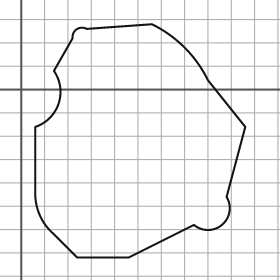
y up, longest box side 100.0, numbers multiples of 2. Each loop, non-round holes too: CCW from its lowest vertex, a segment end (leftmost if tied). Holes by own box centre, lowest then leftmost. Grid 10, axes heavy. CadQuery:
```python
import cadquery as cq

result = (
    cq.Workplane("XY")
    .moveTo(24.0, -72.0)
    .lineTo(46.0, -72.0)
    .lineTo(74.0, -58.0)
    .threePointArc((86.0, -58.0), (88.0, -46.0))
    .lineTo(96.0, -16.0)
    .lineTo(80.0, 4.0)
    .threePointArc((70.0, 18.0), (56.0, 28.0))
    .lineTo(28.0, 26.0)
    .threePointArc((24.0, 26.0), (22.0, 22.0))
    .lineTo(14.0, 8.0)
    .threePointArc((16.0, -6.0), (6.0, -16.0))
    .lineTo(6.0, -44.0)
    .threePointArc((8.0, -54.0), (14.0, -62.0))
    .close()
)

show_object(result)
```